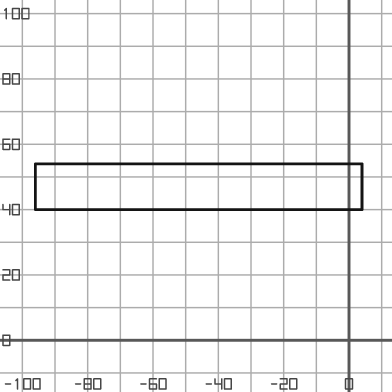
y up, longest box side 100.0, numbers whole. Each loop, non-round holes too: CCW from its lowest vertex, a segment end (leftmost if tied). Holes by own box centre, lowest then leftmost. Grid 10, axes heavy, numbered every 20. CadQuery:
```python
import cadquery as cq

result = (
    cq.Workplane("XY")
    .moveTo(-96.0, 40.0)
    .lineTo(4.0, 40.0)
    .lineTo(4.0, 54.0)
    .lineTo(-96.0, 54.0)
    .close()
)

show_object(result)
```